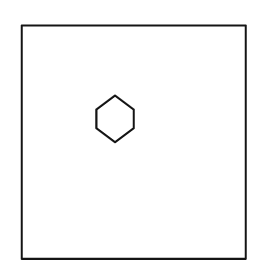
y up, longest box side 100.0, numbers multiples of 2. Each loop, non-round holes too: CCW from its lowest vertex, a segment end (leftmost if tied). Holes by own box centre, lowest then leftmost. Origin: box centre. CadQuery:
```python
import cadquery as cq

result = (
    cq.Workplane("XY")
    .moveTo(-48.0, -50.0)
    .lineTo(48.0, -50.0)
    .lineTo(48.0, 50.0)
    .lineTo(-48.0, 50.0)
    .close()
    .moveTo(-8.0, 0.0)
    .lineTo(0.0, 6.0)
    .lineTo(0.0, 14.0)
    .lineTo(-8.0, 20.0)
    .lineTo(-16.0, 14.0)
    .lineTo(-16.0, 6.0)
    .close()
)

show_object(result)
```